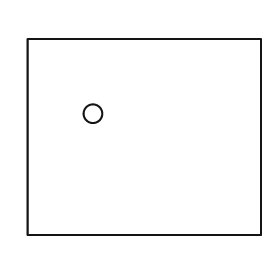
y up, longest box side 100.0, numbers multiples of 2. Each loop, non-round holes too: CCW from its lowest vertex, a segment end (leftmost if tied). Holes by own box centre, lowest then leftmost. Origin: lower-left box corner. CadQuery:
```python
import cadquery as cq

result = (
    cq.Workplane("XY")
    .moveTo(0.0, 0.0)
    .lineTo(100.0, 0.0)
    .lineTo(100.0, 84.0)
    .lineTo(0.0, 84.0)
    .close()
    .moveTo(28.0, 52.0)
    .circle(4.0)
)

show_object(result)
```